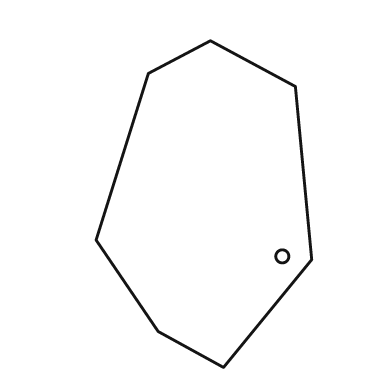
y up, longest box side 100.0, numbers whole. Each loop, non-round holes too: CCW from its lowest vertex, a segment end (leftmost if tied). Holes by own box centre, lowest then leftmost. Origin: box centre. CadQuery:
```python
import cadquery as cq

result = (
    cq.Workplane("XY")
    .moveTo(6.0, -50.0)
    .lineTo(33.0, -17.0)
    .lineTo(28.0, 36.0)
    .lineTo(2.0, 50.0)
    .lineTo(-17.0, 40.0)
    .lineTo(-33.0, -11.0)
    .lineTo(-14.0, -39.0)
    .close()
    .moveTo(24.0, -16.0)
    .circle(2.0)
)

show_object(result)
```